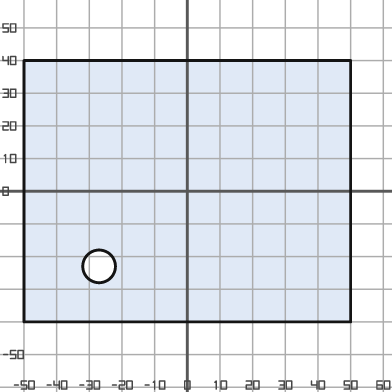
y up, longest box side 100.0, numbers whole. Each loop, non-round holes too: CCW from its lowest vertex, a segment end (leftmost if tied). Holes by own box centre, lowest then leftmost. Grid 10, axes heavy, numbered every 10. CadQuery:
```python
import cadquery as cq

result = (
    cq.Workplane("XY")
    .moveTo(-50.0, -40.0)
    .lineTo(50.0, -40.0)
    .lineTo(50.0, 40.0)
    .lineTo(-50.0, 40.0)
    .close()
    .moveTo(-27.0, -23.0)
    .circle(5.0)
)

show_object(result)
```